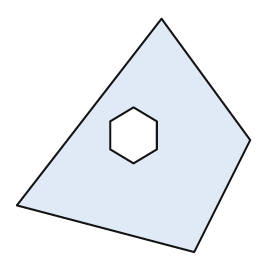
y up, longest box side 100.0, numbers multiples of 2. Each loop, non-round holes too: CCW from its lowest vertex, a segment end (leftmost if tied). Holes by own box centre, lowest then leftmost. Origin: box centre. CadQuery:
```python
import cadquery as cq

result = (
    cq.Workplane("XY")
    .moveTo(26.0, -50.0)
    .lineTo(50.0, -2.0)
    .lineTo(12.0, 50.0)
    .lineTo(-50.0, -30.0)
    .close()
    .moveTo(0.0, -12.0)
    .lineTo(10.0, -6.0)
    .lineTo(10.0, 6.0)
    .lineTo(0.0, 12.0)
    .lineTo(-10.0, 6.0)
    .lineTo(-10.0, -6.0)
    .close()
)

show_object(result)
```